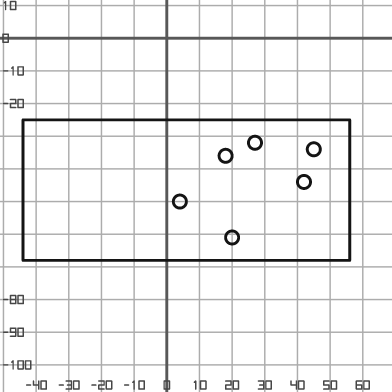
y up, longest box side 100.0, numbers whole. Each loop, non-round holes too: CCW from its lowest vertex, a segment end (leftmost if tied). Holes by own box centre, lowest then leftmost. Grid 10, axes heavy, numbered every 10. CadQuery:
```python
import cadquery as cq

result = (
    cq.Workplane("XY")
    .moveTo(-44.0, -68.0)
    .lineTo(56.0, -68.0)
    .lineTo(56.0, -25.0)
    .lineTo(-44.0, -25.0)
    .close()
    .moveTo(20.0, -61.0)
    .circle(2.0)
    .moveTo(4.0, -50.0)
    .circle(2.0)
    .moveTo(42.0, -44.0)
    .circle(2.0)
    .moveTo(18.0, -36.0)
    .circle(2.0)
    .moveTo(45.0, -34.0)
    .circle(2.0)
    .moveTo(27.0, -32.0)
    .circle(2.0)
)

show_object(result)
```